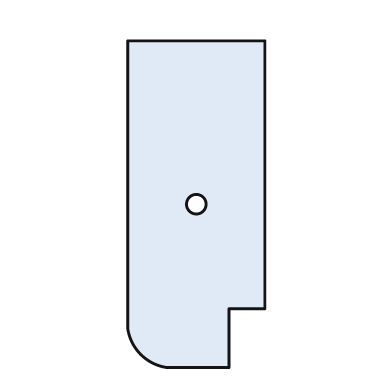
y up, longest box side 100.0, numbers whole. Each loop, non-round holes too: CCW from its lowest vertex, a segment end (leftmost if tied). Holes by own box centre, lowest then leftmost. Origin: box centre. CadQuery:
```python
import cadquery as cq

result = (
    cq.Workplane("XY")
    .moveTo(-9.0, -50.0)
    .lineTo(10.0, -50.0)
    .lineTo(10.0, -32.0)
    .lineTo(21.0, -32.0)
    .lineTo(21.0, 50.0)
    .lineTo(-21.0, 50.0)
    .lineTo(-21.0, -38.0)
    .threePointArc((-17.0, -46.0), (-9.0, -50.0))
    .close()
    .moveTo(0.0, 0.0)
    .circle(3.0)
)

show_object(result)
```